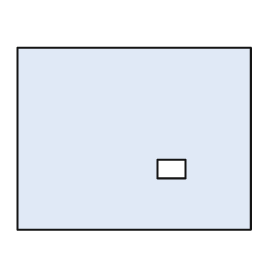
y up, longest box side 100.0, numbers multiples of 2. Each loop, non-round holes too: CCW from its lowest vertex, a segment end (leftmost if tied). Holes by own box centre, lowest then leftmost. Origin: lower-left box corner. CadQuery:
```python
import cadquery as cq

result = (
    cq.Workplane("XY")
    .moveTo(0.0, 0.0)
    .lineTo(100.0, 0.0)
    .lineTo(100.0, 78.0)
    .lineTo(0.0, 78.0)
    .close()
    .moveTo(60.0, 22.0)
    .lineTo(72.0, 22.0)
    .lineTo(72.0, 30.0)
    .lineTo(60.0, 30.0)
    .close()
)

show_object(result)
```